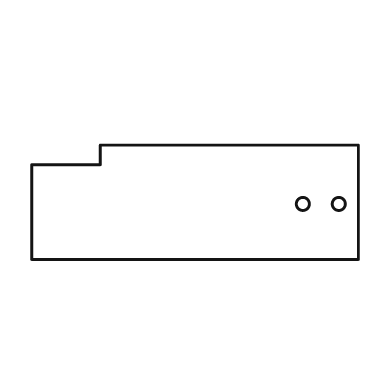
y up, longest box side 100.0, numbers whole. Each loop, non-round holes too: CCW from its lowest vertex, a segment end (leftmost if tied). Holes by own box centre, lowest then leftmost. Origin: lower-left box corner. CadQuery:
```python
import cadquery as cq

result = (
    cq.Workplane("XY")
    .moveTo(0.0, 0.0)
    .lineTo(100.0, 0.0)
    .lineTo(100.0, 35.0)
    .lineTo(21.0, 35.0)
    .lineTo(21.0, 29.0)
    .lineTo(0.0, 29.0)
    .close()
    .moveTo(83.0, 17.0)
    .circle(2.0)
    .moveTo(94.0, 17.0)
    .circle(2.0)
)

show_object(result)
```